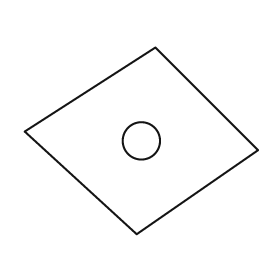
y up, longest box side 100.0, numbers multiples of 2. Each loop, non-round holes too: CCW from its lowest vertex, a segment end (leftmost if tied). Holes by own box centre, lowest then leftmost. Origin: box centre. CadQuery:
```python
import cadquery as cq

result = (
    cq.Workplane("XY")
    .moveTo(-2.0, -40.0)
    .lineTo(50.0, -4.0)
    .lineTo(6.0, 40.0)
    .lineTo(-50.0, 4.0)
    .close()
    .moveTo(0.0, 0.0)
    .circle(8.0)
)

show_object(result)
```